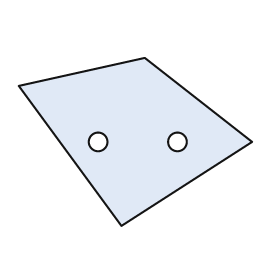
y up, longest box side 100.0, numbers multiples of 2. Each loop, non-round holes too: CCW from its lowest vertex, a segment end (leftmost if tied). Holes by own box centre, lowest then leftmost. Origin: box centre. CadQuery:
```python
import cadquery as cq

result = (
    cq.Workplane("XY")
    .moveTo(-6.0, -36.0)
    .lineTo(50.0, 0.0)
    .lineTo(4.0, 36.0)
    .lineTo(-50.0, 24.0)
    .close()
    .moveTo(-16.0, 0.0)
    .circle(4.0)
    .moveTo(18.0, 0.0)
    .circle(4.0)
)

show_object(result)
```